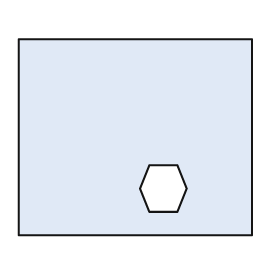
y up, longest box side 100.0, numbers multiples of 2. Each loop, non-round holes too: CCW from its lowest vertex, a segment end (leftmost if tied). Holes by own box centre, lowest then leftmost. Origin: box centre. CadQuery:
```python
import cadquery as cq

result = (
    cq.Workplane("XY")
    .moveTo(-50.0, -42.0)
    .lineTo(50.0, -42.0)
    .lineTo(50.0, 42.0)
    .lineTo(-50.0, 42.0)
    .close()
    .moveTo(6.0, -32.0)
    .lineTo(18.0, -32.0)
    .lineTo(22.0, -22.0)
    .lineTo(18.0, -12.0)
    .lineTo(6.0, -12.0)
    .lineTo(2.0, -22.0)
    .close()
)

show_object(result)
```